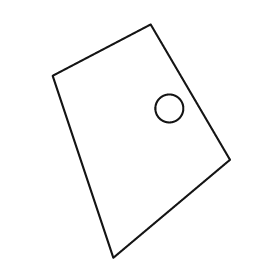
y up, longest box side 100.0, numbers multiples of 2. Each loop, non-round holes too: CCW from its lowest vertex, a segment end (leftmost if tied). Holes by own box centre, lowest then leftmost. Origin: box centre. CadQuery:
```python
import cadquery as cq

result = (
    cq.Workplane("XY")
    .moveTo(-12.0, -50.0)
    .lineTo(38.0, -8.0)
    .lineTo(4.0, 50.0)
    .lineTo(-38.0, 28.0)
    .close()
    .moveTo(12.0, 14.0)
    .circle(6.0)
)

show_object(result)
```